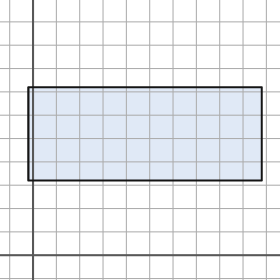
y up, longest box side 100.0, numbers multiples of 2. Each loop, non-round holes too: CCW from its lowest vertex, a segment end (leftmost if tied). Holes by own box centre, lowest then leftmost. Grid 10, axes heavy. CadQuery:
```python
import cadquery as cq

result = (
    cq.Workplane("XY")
    .moveTo(-2.0, 32.0)
    .lineTo(98.0, 32.0)
    .lineTo(98.0, 72.0)
    .lineTo(-2.0, 72.0)
    .close()
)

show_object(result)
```